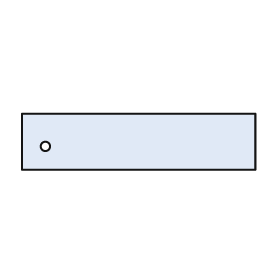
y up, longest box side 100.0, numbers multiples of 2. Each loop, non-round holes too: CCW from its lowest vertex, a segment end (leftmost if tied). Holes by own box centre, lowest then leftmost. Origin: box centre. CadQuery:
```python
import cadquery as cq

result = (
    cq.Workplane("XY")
    .moveTo(-50.0, -12.0)
    .lineTo(50.0, -12.0)
    .lineTo(50.0, 12.0)
    .lineTo(-50.0, 12.0)
    .close()
    .moveTo(-40.0, -2.0)
    .circle(2.0)
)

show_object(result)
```